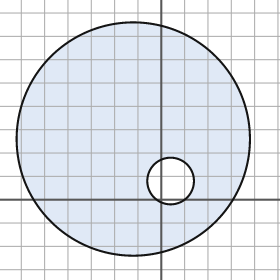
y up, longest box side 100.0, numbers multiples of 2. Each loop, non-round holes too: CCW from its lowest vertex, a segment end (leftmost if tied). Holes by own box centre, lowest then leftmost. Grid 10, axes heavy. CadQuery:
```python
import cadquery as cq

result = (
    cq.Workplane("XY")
    .moveTo(-12.0, 26.0)
    .circle(50.0)
    .moveTo(4.0, 8.0)
    .circle(10.0)
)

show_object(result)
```